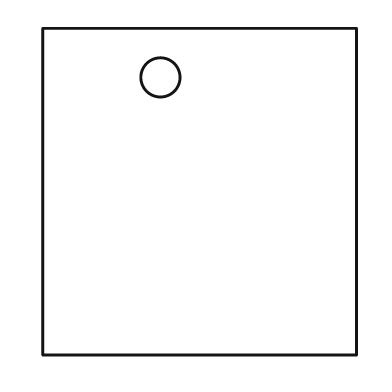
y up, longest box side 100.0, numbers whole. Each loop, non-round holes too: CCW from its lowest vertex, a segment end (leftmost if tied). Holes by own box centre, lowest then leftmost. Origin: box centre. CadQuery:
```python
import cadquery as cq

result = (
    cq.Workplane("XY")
    .moveTo(-48.0, -50.0)
    .lineTo(48.0, -50.0)
    .lineTo(48.0, 50.0)
    .lineTo(-48.0, 50.0)
    .close()
    .moveTo(-12.0, 35.0)
    .circle(6.0)
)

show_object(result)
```